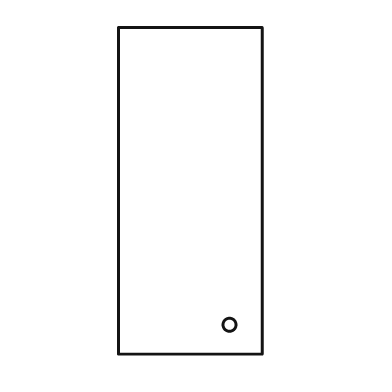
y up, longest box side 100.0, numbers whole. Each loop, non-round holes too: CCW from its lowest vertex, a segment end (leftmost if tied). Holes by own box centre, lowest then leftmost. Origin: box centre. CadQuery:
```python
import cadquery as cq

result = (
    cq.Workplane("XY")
    .moveTo(-22.0, -50.0)
    .lineTo(22.0, -50.0)
    .lineTo(22.0, 50.0)
    .lineTo(-22.0, 50.0)
    .close()
    .moveTo(12.0, -41.0)
    .circle(2.0)
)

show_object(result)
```